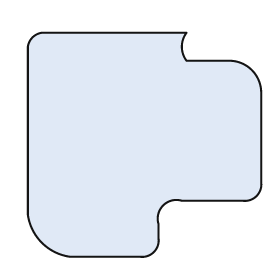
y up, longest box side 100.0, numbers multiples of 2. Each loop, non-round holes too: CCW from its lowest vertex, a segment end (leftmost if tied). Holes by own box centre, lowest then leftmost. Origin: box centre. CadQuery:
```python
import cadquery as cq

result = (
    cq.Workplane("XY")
    .moveTo(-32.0, -48.0)
    .lineTo(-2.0, -48.0)
    .threePointArc((4.0, -46.0), (6.0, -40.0))
    .lineTo(6.0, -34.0)
    .threePointArc((8.0, -26.0), (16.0, -24.0))
    .lineTo(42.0, -24.0)
    .threePointArc((48.0, -22.0), (50.0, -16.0))
    .lineTo(50.0, 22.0)
    .threePointArc((46.0, 32.0), (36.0, 36.0))
    .lineTo(18.0, 36.0)
    .threePointArc((16.0, 42.0), (18.0, 48.0))
    .lineTo(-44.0, 48.0)
    .threePointArc((-48.0, 46.0), (-50.0, 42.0))
    .lineTo(-50.0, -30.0)
    .threePointArc((-44.0, -42.0), (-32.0, -48.0))
    .close()
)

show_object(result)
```